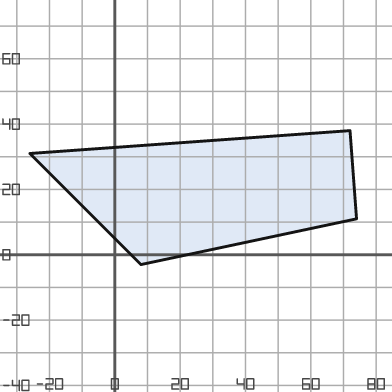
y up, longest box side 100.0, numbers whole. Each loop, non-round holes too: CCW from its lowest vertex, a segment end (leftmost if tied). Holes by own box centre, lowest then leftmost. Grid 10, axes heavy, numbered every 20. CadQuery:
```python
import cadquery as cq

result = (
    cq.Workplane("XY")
    .moveTo(8.0, -3.0)
    .lineTo(74.0, 11.0)
    .lineTo(72.0, 38.0)
    .lineTo(-26.0, 31.0)
    .close()
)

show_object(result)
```